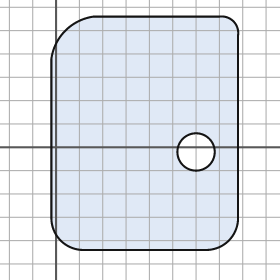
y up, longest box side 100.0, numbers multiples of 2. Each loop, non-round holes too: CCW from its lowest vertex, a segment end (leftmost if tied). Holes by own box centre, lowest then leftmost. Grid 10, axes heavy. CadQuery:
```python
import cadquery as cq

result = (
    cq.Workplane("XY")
    .moveTo(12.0, -44.0)
    .lineTo(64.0, -44.0)
    .threePointArc((74.0, -40.0), (78.0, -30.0))
    .lineTo(78.0, 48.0)
    .threePointArc((76.0, 54.0), (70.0, 56.0))
    .lineTo(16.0, 56.0)
    .threePointArc((4.0, 50.0), (-2.0, 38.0))
    .lineTo(-2.0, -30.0)
    .threePointArc((2.0, -40.0), (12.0, -44.0))
    .close()
    .moveTo(60.0, -2.0)
    .circle(8.0)
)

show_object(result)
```